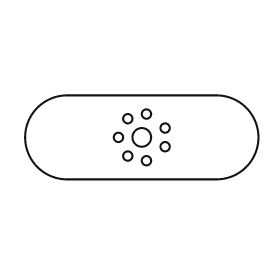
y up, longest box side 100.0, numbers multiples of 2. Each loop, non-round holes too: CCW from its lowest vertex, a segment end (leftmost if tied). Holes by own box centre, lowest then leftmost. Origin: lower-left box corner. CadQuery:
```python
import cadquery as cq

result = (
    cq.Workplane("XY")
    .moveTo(18.0, 0.0)
    .lineTo(82.0, 0.0)
    .threePointArc((100.0, 18.0), (82.0, 36.0))
    .lineTo(18.0, 36.0)
    .threePointArc((0.0, 18.0), (18.0, 0.0))
    .close()
    .moveTo(52.0, 8.0)
    .circle(2.0)
    .moveTo(44.0, 10.0)
    .circle(2.0)
    .moveTo(60.0, 14.0)
    .circle(2.0)
    .moveTo(40.0, 18.0)
    .circle(2.0)
    .moveTo(50.0, 18.0)
    .circle(4.0)
    .moveTo(60.0, 22.0)
    .circle(2.0)
    .moveTo(44.0, 26.0)
    .circle(2.0)
    .moveTo(52.0, 28.0)
    .circle(2.0)
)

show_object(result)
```